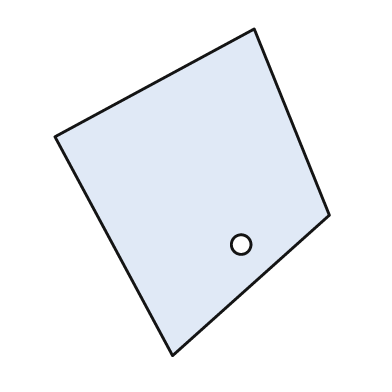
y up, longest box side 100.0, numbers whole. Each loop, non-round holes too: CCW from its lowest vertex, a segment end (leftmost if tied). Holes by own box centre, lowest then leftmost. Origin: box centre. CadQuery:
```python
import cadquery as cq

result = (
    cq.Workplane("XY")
    .moveTo(-6.0, -50.0)
    .lineTo(42.0, -7.0)
    .lineTo(19.0, 50.0)
    .lineTo(-42.0, 17.0)
    .close()
    .moveTo(15.0, -16.0)
    .circle(3.0)
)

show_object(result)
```